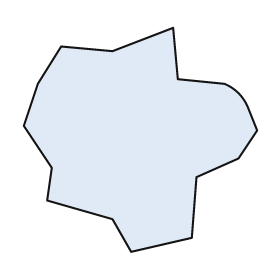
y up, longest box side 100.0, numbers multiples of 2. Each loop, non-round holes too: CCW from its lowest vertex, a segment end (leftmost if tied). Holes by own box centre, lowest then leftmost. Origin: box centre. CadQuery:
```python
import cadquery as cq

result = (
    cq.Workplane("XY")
    .moveTo(-4.0, -48.0)
    .lineTo(22.0, -42.0)
    .lineTo(24.0, -16.0)
    .lineTo(42.0, -8.0)
    .lineTo(50.0, 4.0)
    .lineTo(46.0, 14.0)
    .threePointArc((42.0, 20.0), (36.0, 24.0))
    .lineTo(16.0, 26.0)
    .lineTo(14.0, 48.0)
    .lineTo(-12.0, 38.0)
    .lineTo(-34.0, 40.0)
    .lineTo(-44.0, 24.0)
    .lineTo(-50.0, 6.0)
    .lineTo(-38.0, -12.0)
    .lineTo(-40.0, -26.0)
    .lineTo(-12.0, -34.0)
    .close()
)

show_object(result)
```